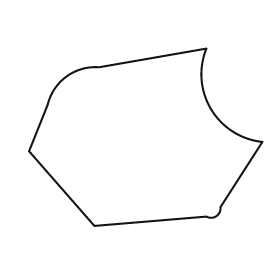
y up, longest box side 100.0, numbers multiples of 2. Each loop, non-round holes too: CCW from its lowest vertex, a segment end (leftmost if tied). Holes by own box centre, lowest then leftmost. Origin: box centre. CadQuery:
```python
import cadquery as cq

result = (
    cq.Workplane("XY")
    .moveTo(-22.0, -38.0)
    .lineTo(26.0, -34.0)
    .threePointArc((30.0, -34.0), (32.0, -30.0))
    .lineTo(50.0, -2.0)
    .threePointArc((28.0, 12.0), (26.0, 38.0))
    .lineTo(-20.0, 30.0)
    .threePointArc((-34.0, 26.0), (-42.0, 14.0))
    .lineTo(-50.0, -6.0)
    .close()
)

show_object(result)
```